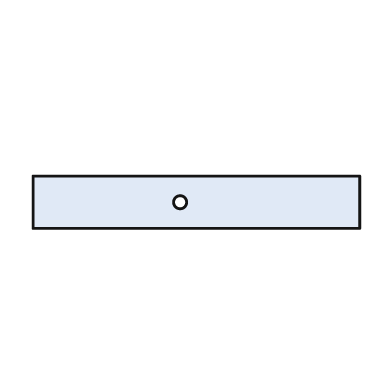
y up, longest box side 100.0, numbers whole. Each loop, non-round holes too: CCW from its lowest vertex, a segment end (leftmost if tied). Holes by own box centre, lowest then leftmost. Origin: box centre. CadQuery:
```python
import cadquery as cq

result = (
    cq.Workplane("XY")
    .moveTo(-50.0, -8.0)
    .lineTo(50.0, -8.0)
    .lineTo(50.0, 8.0)
    .lineTo(-50.0, 8.0)
    .close()
    .moveTo(-5.0, 0.0)
    .circle(2.0)
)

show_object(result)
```